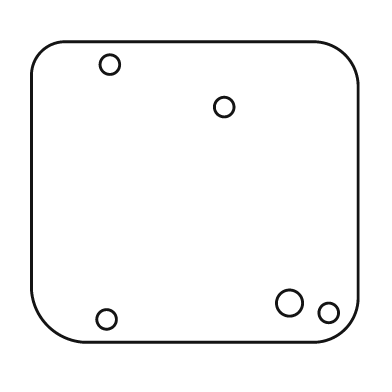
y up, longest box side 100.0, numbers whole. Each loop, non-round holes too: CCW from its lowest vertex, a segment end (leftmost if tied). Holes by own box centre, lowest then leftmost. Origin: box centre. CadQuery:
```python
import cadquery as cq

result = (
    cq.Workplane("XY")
    .moveTo(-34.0, -46.0)
    .lineTo(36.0, -46.0)
    .threePointArc((46.0, -42.0), (50.0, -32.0))
    .lineTo(50.0, 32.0)
    .threePointArc((46.0, 42.0), (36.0, 46.0))
    .lineTo(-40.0, 46.0)
    .threePointArc((-47.0, 43.0), (-50.0, 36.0))
    .lineTo(-50.0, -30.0)
    .threePointArc((-45.0, -41.0), (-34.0, -46.0))
    .close()
    .moveTo(-27.0, -39.0)
    .circle(3.0)
    .moveTo(41.0, -37.0)
    .circle(3.0)
    .moveTo(29.0, -34.0)
    .circle(4.0)
    .moveTo(9.0, 26.0)
    .circle(3.0)
    .moveTo(-26.0, 39.0)
    .circle(3.0)
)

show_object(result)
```